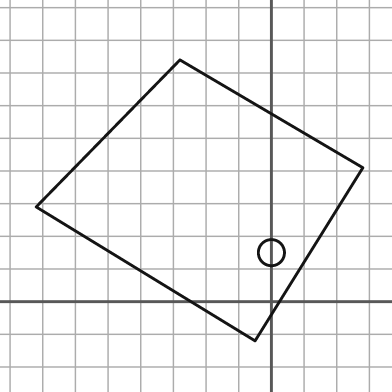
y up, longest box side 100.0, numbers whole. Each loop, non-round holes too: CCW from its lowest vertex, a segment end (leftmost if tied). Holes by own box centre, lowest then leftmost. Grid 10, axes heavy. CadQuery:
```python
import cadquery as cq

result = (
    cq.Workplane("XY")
    .moveTo(-5.0, -12.0)
    .lineTo(28.0, 41.0)
    .lineTo(-28.0, 74.0)
    .lineTo(-72.0, 29.0)
    .close()
    .moveTo(0.0, 15.0)
    .circle(4.0)
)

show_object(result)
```